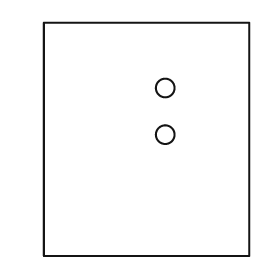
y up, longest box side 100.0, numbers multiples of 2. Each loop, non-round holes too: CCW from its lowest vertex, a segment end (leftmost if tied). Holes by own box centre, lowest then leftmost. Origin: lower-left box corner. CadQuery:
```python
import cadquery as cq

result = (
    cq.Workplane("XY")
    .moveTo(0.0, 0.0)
    .lineTo(88.0, 0.0)
    .lineTo(88.0, 100.0)
    .lineTo(0.0, 100.0)
    .close()
    .moveTo(52.0, 52.0)
    .circle(4.0)
    .moveTo(52.0, 72.0)
    .circle(4.0)
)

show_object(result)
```